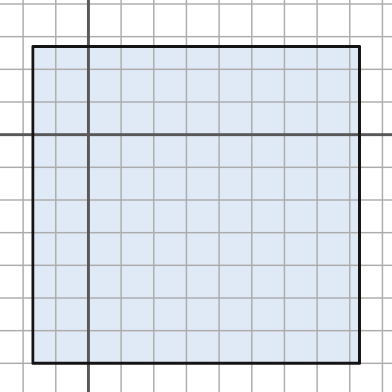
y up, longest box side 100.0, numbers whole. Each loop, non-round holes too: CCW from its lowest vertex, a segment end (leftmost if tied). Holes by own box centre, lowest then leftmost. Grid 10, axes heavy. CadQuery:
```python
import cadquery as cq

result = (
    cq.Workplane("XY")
    .moveTo(-17.0, -70.0)
    .lineTo(83.0, -70.0)
    .lineTo(83.0, 27.0)
    .lineTo(-17.0, 27.0)
    .close()
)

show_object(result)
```